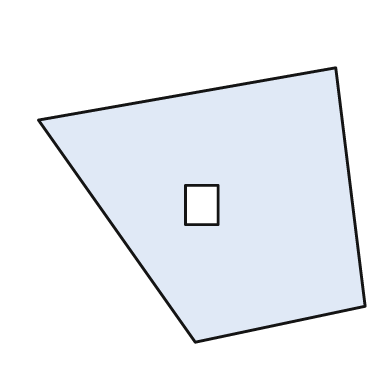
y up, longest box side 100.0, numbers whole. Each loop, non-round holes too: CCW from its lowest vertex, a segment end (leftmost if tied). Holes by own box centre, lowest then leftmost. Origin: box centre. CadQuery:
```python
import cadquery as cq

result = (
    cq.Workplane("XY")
    .moveTo(-2.0, -42.0)
    .lineTo(50.0, -31.0)
    .lineTo(41.0, 42.0)
    .lineTo(-50.0, 26.0)
    .close()
    .moveTo(-5.0, -6.0)
    .lineTo(5.0, -6.0)
    .lineTo(5.0, 6.0)
    .lineTo(-5.0, 6.0)
    .close()
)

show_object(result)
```